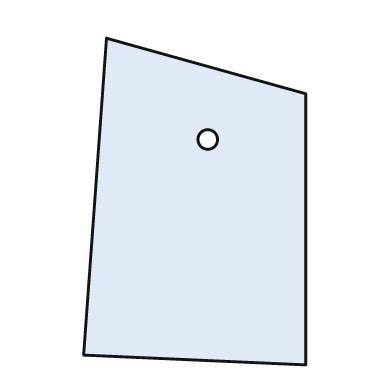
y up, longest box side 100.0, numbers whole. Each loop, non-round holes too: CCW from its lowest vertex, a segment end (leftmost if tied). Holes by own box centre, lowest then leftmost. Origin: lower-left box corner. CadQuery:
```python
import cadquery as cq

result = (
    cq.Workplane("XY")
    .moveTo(68.0, 0.0)
    .lineTo(68.0, 83.0)
    .lineTo(7.0, 100.0)
    .lineTo(0.0, 3.0)
    .close()
    .moveTo(38.0, 69.0)
    .circle(3.0)
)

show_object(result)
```